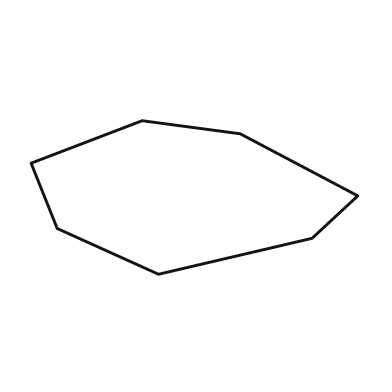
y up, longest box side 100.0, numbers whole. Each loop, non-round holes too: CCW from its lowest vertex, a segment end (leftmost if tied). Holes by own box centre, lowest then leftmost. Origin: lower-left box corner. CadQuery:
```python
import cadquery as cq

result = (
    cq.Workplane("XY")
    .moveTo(39.0, 0.0)
    .lineTo(86.0, 11.0)
    .lineTo(100.0, 24.0)
    .lineTo(64.0, 43.0)
    .lineTo(34.0, 47.0)
    .lineTo(0.0, 34.0)
    .lineTo(8.0, 14.0)
    .close()
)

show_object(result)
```